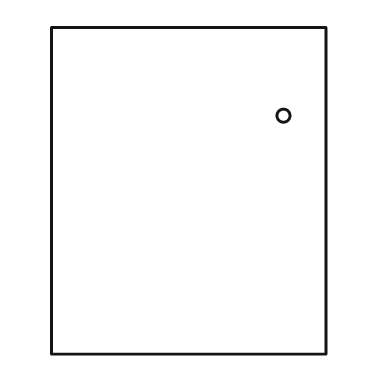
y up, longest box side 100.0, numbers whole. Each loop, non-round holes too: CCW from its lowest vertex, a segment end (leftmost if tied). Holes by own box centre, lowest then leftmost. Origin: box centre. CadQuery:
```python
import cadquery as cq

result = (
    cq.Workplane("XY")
    .moveTo(-42.0, -50.0)
    .lineTo(42.0, -50.0)
    .lineTo(42.0, 50.0)
    .lineTo(-42.0, 50.0)
    .close()
    .moveTo(29.0, 23.0)
    .circle(2.0)
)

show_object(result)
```